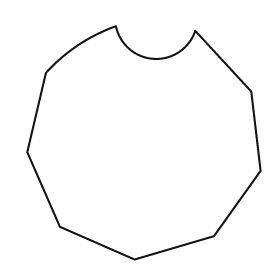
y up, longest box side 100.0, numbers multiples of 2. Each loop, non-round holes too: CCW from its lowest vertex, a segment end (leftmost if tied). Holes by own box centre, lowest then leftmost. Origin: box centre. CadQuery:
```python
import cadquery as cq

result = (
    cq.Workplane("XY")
    .moveTo(-4.0, -50.0)
    .lineTo(30.0, -40.0)
    .lineTo(50.0, -12.0)
    .lineTo(46.0, 22.0)
    .lineTo(22.0, 48.0)
    .threePointArc((4.0, 36.0), (-12.0, 50.0))
    .threePointArc((-28.0, 42.0), (-42.0, 30.0))
    .lineTo(-50.0, -4.0)
    .lineTo(-36.0, -36.0)
    .close()
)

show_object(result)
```